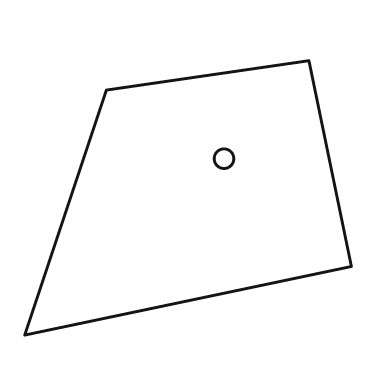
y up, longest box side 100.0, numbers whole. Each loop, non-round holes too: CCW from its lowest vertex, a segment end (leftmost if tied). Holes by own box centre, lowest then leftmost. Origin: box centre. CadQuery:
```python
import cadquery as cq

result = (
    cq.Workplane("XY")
    .moveTo(-50.0, -42.0)
    .lineTo(50.0, -21.0)
    .lineTo(37.0, 42.0)
    .lineTo(-25.0, 33.0)
    .close()
    .moveTo(11.0, 12.0)
    .circle(3.0)
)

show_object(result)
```